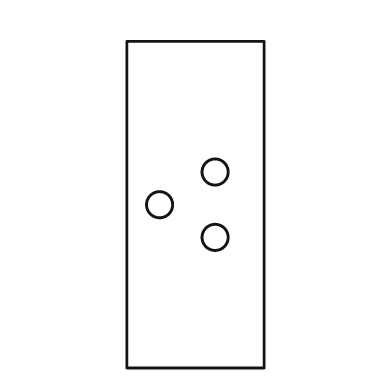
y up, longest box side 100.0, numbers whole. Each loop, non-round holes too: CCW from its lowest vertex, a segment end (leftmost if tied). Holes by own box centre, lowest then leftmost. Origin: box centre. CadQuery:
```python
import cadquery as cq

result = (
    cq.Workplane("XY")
    .moveTo(-21.0, -50.0)
    .lineTo(21.0, -50.0)
    .lineTo(21.0, 50.0)
    .lineTo(-21.0, 50.0)
    .close()
    .moveTo(6.0, -10.0)
    .circle(4.0)
    .moveTo(-11.0, 0.0)
    .circle(4.0)
    .moveTo(6.0, 10.0)
    .circle(4.0)
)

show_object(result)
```